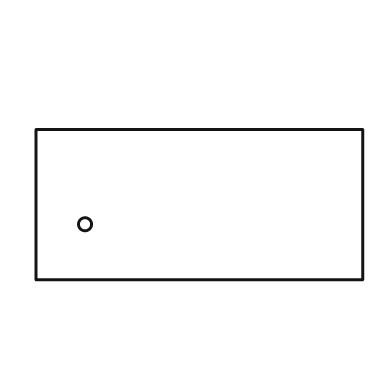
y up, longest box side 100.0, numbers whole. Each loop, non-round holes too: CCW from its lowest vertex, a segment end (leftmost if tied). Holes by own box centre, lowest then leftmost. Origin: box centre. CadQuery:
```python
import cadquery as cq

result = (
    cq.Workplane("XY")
    .moveTo(-50.0, -23.0)
    .lineTo(50.0, -23.0)
    .lineTo(50.0, 23.0)
    .lineTo(-50.0, 23.0)
    .close()
    .moveTo(-35.0, -6.0)
    .circle(2.0)
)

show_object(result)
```